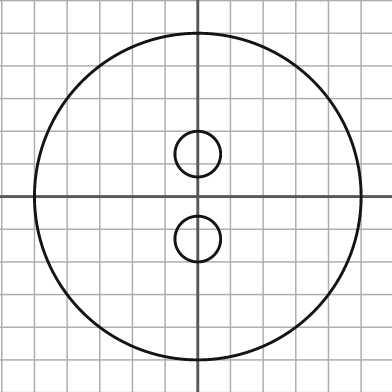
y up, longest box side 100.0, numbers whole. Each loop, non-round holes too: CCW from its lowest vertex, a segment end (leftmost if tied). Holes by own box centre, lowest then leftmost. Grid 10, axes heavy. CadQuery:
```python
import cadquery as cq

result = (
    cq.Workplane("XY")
    .moveTo(0.0, 0.0)
    .circle(50.0)
    .moveTo(0.0, -13.0)
    .circle(7.0)
    .moveTo(0.0, 13.0)
    .circle(7.0)
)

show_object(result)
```